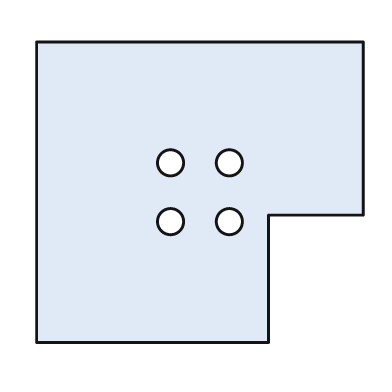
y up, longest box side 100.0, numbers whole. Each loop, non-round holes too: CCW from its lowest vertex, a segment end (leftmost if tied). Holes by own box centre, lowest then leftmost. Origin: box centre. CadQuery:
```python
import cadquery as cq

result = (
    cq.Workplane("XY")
    .moveTo(-50.0, -46.0)
    .lineTo(21.0, -46.0)
    .lineTo(21.0, -7.0)
    .lineTo(50.0, -7.0)
    .lineTo(50.0, 46.0)
    .lineTo(-50.0, 46.0)
    .close()
    .moveTo(-9.0, -9.0)
    .circle(4.0)
    .moveTo(9.0, -9.0)
    .circle(4.0)
    .moveTo(-9.0, 9.0)
    .circle(4.0)
    .moveTo(9.0, 9.0)
    .circle(4.0)
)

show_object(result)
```